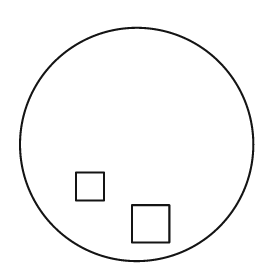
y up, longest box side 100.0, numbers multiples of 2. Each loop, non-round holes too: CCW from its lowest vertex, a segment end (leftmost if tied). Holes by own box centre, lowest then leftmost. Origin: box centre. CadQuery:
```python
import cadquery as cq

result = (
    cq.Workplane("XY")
    .moveTo(0.0, 0.0)
    .circle(50.0)
    .moveTo(-2.0, -42.0)
    .lineTo(14.0, -42.0)
    .lineTo(14.0, -26.0)
    .lineTo(-2.0, -26.0)
    .close()
    .moveTo(-26.0, -24.0)
    .lineTo(-14.0, -24.0)
    .lineTo(-14.0, -12.0)
    .lineTo(-26.0, -12.0)
    .close()
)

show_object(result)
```